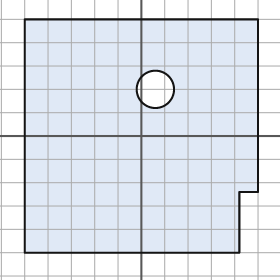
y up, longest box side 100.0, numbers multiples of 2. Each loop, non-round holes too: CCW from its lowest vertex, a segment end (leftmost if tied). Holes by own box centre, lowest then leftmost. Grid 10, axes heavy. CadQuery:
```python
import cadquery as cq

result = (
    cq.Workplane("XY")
    .moveTo(-50.0, -50.0)
    .lineTo(42.0, -50.0)
    .lineTo(42.0, -24.0)
    .lineTo(50.0, -24.0)
    .lineTo(50.0, 50.0)
    .lineTo(-50.0, 50.0)
    .close()
    .moveTo(6.0, 20.0)
    .circle(8.0)
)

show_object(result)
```